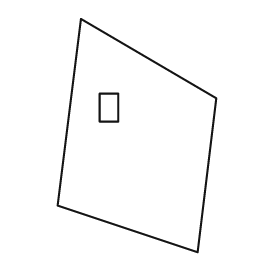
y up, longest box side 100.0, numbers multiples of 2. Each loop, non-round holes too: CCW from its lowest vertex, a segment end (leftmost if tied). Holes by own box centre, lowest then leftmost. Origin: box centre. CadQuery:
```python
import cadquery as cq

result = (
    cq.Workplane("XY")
    .moveTo(26.0, -50.0)
    .lineTo(34.0, 16.0)
    .lineTo(-24.0, 50.0)
    .lineTo(-34.0, -30.0)
    .close()
    .moveTo(-16.0, 6.0)
    .lineTo(-8.0, 6.0)
    .lineTo(-8.0, 18.0)
    .lineTo(-16.0, 18.0)
    .close()
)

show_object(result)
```